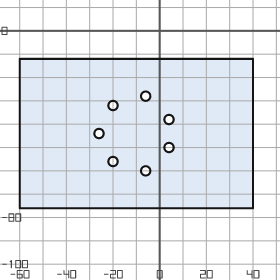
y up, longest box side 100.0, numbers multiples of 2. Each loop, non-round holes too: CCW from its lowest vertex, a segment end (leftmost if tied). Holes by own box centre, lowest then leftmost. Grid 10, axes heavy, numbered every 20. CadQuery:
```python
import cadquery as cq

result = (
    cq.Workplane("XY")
    .moveTo(-60.0, -76.0)
    .lineTo(40.0, -76.0)
    .lineTo(40.0, -12.0)
    .lineTo(-60.0, -12.0)
    .close()
    .moveTo(-6.0, -60.0)
    .circle(2.0)
    .moveTo(-20.0, -56.0)
    .circle(2.0)
    .moveTo(4.0, -50.0)
    .circle(2.0)
    .moveTo(-26.0, -44.0)
    .circle(2.0)
    .moveTo(4.0, -38.0)
    .circle(2.0)
    .moveTo(-20.0, -32.0)
    .circle(2.0)
    .moveTo(-6.0, -28.0)
    .circle(2.0)
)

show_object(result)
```